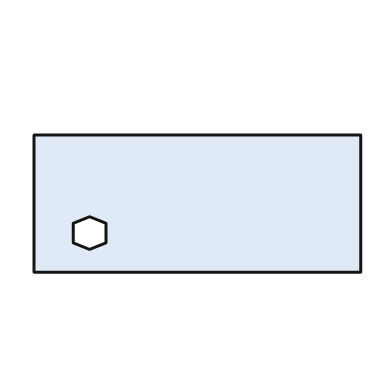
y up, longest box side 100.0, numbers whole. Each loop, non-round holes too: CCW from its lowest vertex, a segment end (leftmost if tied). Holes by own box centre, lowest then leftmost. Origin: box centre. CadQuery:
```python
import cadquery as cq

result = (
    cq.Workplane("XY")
    .moveTo(-50.0, -21.0)
    .lineTo(50.0, -21.0)
    .lineTo(50.0, 21.0)
    .lineTo(-50.0, 21.0)
    .close()
    .moveTo(-33.0, -14.0)
    .lineTo(-28.0, -12.0)
    .lineTo(-28.0, -6.0)
    .lineTo(-33.0, -4.0)
    .lineTo(-38.0, -6.0)
    .lineTo(-38.0, -12.0)
    .close()
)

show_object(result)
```